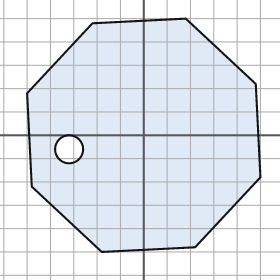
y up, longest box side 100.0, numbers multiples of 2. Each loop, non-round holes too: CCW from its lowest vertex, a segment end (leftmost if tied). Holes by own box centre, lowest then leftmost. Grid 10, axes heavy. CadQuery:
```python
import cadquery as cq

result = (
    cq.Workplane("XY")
    .moveTo(-18.0, -50.0)
    .lineTo(22.0, -48.0)
    .lineTo(50.0, -18.0)
    .lineTo(48.0, 22.0)
    .lineTo(18.0, 50.0)
    .lineTo(-22.0, 48.0)
    .lineTo(-50.0, 18.0)
    .lineTo(-48.0, -22.0)
    .close()
    .moveTo(-32.0, -6.0)
    .circle(6.0)
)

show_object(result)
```